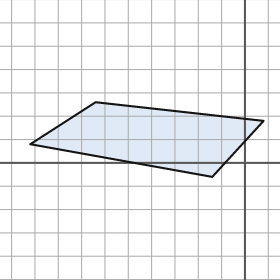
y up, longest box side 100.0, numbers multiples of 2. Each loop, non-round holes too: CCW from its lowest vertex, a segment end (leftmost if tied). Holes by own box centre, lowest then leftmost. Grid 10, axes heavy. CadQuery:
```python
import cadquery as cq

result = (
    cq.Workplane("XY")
    .moveTo(-14.0, -6.0)
    .lineTo(8.0, 18.0)
    .lineTo(-64.0, 26.0)
    .lineTo(-92.0, 8.0)
    .close()
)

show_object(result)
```